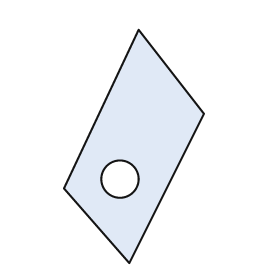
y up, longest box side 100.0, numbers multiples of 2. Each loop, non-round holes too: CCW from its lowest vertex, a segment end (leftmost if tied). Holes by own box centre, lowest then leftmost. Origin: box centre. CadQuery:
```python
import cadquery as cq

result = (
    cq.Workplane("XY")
    .moveTo(-2.0, -50.0)
    .lineTo(30.0, 14.0)
    .lineTo(2.0, 50.0)
    .lineTo(-30.0, -18.0)
    .close()
    .moveTo(-6.0, -14.0)
    .circle(8.0)
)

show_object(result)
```